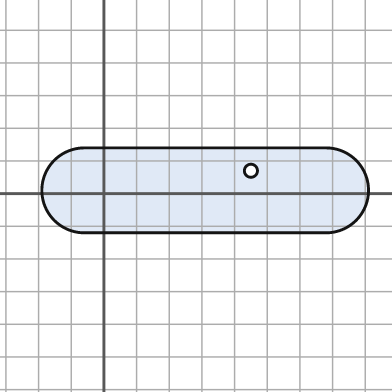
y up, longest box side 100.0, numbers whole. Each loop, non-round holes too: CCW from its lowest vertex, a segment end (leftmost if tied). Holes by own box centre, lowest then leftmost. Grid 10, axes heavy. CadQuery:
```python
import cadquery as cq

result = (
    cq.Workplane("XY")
    .moveTo(-6.0, -12.0)
    .lineTo(68.0, -12.0)
    .threePointArc((81.0, 1.0), (68.0, 14.0))
    .lineTo(-6.0, 14.0)
    .threePointArc((-19.0, 1.0), (-6.0, -12.0))
    .close()
    .moveTo(45.0, 7.0)
    .circle(2.0)
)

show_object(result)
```